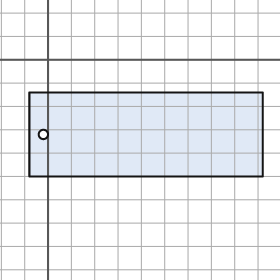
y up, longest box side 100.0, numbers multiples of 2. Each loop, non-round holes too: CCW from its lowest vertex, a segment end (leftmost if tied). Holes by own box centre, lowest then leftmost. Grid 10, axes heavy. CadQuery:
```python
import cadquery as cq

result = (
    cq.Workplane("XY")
    .moveTo(-8.0, -50.0)
    .lineTo(92.0, -50.0)
    .lineTo(92.0, -14.0)
    .lineTo(-8.0, -14.0)
    .close()
    .moveTo(-2.0, -32.0)
    .circle(2.0)
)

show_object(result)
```